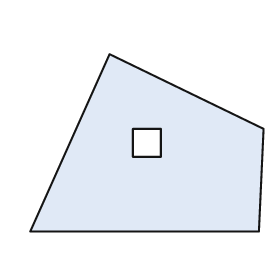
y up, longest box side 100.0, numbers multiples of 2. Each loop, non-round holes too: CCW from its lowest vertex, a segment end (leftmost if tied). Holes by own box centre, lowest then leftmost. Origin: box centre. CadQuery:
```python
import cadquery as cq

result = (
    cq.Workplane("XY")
    .moveTo(-50.0, -38.0)
    .lineTo(48.0, -38.0)
    .lineTo(50.0, 6.0)
    .lineTo(-16.0, 38.0)
    .close()
    .moveTo(-6.0, -6.0)
    .lineTo(6.0, -6.0)
    .lineTo(6.0, 6.0)
    .lineTo(-6.0, 6.0)
    .close()
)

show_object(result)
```